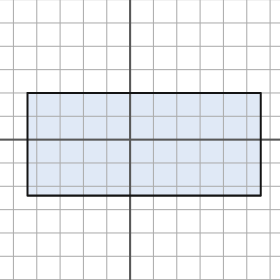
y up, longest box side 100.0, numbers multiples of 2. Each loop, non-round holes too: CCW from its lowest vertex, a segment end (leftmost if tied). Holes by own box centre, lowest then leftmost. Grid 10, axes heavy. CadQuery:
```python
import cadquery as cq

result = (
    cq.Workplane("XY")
    .moveTo(-44.0, -24.0)
    .lineTo(56.0, -24.0)
    .lineTo(56.0, 20.0)
    .lineTo(-44.0, 20.0)
    .close()
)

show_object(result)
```